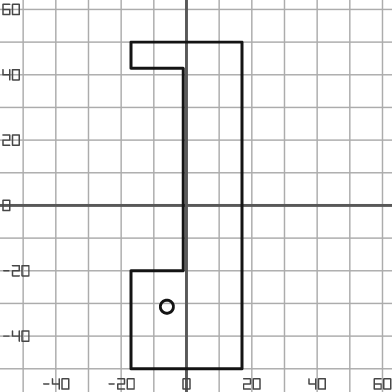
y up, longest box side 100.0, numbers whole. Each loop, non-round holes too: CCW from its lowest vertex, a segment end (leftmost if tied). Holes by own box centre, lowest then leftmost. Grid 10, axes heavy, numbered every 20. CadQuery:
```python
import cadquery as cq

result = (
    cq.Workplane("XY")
    .moveTo(-17.0, -50.0)
    .lineTo(17.0, -50.0)
    .lineTo(17.0, 50.0)
    .lineTo(-17.0, 50.0)
    .lineTo(-17.0, 42.0)
    .lineTo(-1.0, 42.0)
    .lineTo(-1.0, -20.0)
    .lineTo(-17.0, -20.0)
    .close()
    .moveTo(-6.0, -31.0)
    .circle(2.0)
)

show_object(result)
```